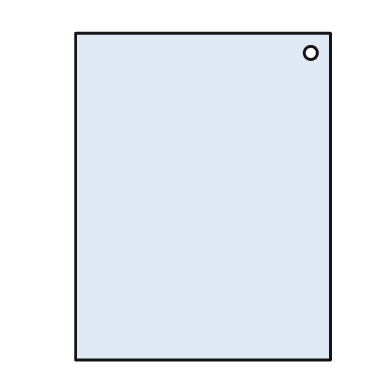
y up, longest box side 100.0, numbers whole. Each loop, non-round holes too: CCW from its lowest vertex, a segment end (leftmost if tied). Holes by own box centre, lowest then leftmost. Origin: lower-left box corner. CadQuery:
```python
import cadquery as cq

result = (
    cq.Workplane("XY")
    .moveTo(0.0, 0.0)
    .lineTo(78.0, 0.0)
    .lineTo(78.0, 100.0)
    .lineTo(0.0, 100.0)
    .close()
    .moveTo(72.0, 94.0)
    .circle(2.0)
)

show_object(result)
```